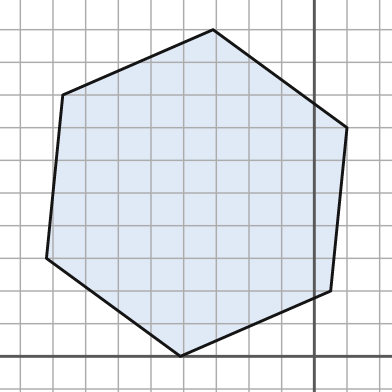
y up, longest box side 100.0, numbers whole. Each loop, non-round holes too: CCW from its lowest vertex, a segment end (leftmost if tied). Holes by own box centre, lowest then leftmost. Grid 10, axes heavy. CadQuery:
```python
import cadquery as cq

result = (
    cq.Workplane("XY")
    .moveTo(-41.0, 0.0)
    .lineTo(5.0, 20.0)
    .lineTo(10.0, 70.0)
    .lineTo(-31.0, 100.0)
    .lineTo(-77.0, 80.0)
    .lineTo(-82.0, 30.0)
    .close()
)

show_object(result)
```